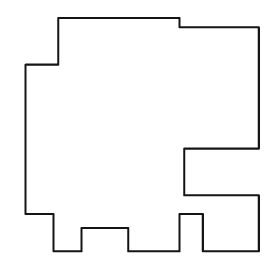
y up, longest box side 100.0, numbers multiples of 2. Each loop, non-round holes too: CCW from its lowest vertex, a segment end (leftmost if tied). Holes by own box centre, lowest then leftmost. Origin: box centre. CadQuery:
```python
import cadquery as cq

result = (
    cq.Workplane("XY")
    .moveTo(-38.0, -50.0)
    .lineTo(-26.0, -50.0)
    .lineTo(-26.0, -40.0)
    .lineTo(-6.0, -40.0)
    .lineTo(-6.0, -50.0)
    .lineTo(16.0, -50.0)
    .lineTo(16.0, -34.0)
    .lineTo(26.0, -34.0)
    .lineTo(26.0, -50.0)
    .lineTo(50.0, -50.0)
    .lineTo(50.0, -26.0)
    .lineTo(18.0, -26.0)
    .lineTo(18.0, -6.0)
    .lineTo(50.0, -6.0)
    .lineTo(50.0, 46.0)
    .lineTo(16.0, 46.0)
    .lineTo(16.0, 50.0)
    .lineTo(-36.0, 50.0)
    .lineTo(-36.0, 30.0)
    .lineTo(-50.0, 30.0)
    .lineTo(-50.0, -34.0)
    .lineTo(-38.0, -34.0)
    .close()
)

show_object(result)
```